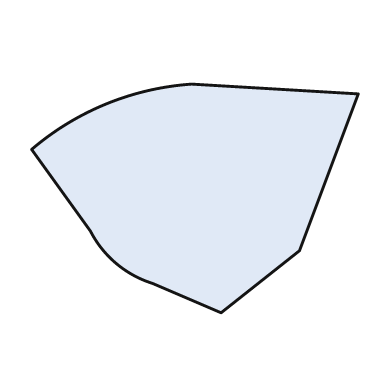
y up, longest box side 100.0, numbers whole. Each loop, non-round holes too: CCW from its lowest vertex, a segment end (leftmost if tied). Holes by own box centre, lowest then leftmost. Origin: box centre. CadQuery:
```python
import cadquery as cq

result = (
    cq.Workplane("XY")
    .moveTo(8.0, -35.0)
    .lineTo(32.0, -16.0)
    .lineTo(50.0, 32.0)
    .lineTo(-1.0, 35.0)
    .threePointArc((-27.0, 29.0), (-50.0, 15.0))
    .lineTo(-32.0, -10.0)
    .threePointArc((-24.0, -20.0), (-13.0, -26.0))
    .close()
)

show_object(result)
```